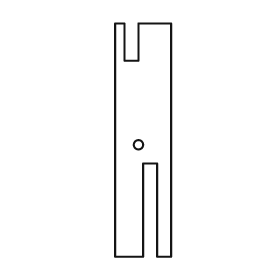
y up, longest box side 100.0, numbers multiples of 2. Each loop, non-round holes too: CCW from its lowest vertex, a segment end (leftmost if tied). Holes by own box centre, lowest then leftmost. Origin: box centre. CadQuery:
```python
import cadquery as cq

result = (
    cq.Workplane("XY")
    .moveTo(-12.0, -50.0)
    .lineTo(0.0, -50.0)
    .lineTo(0.0, -10.0)
    .lineTo(6.0, -10.0)
    .lineTo(6.0, -50.0)
    .lineTo(12.0, -50.0)
    .lineTo(12.0, 50.0)
    .lineTo(-2.0, 50.0)
    .lineTo(-2.0, 34.0)
    .lineTo(-8.0, 34.0)
    .lineTo(-8.0, 50.0)
    .lineTo(-12.0, 50.0)
    .close()
    .moveTo(-2.0, -2.0)
    .circle(2.0)
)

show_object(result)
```